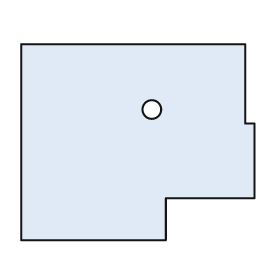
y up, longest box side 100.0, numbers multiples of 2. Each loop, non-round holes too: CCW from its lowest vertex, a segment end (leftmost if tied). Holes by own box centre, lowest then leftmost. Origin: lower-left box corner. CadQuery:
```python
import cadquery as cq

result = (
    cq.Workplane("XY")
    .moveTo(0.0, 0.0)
    .lineTo(62.0, 0.0)
    .lineTo(62.0, 18.0)
    .lineTo(100.0, 18.0)
    .lineTo(100.0, 50.0)
    .lineTo(96.0, 50.0)
    .lineTo(96.0, 84.0)
    .lineTo(0.0, 84.0)
    .close()
    .moveTo(56.0, 56.0)
    .circle(4.0)
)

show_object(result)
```